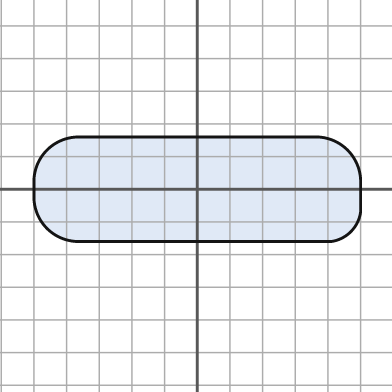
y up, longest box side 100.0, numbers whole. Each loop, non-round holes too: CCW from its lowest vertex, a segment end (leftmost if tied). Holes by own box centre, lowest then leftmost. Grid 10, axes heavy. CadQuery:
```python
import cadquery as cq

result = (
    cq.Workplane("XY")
    .moveTo(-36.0, -16.0)
    .lineTo(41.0, -16.0)
    .threePointArc((47.0, -13.0), (50.0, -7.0))
    .lineTo(50.0, 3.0)
    .threePointArc((46.0, 12.0), (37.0, 16.0))
    .lineTo(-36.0, 16.0)
    .threePointArc((-46.0, 12.0), (-50.0, 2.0))
    .lineTo(-50.0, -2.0)
    .threePointArc((-46.0, -12.0), (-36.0, -16.0))
    .close()
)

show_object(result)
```